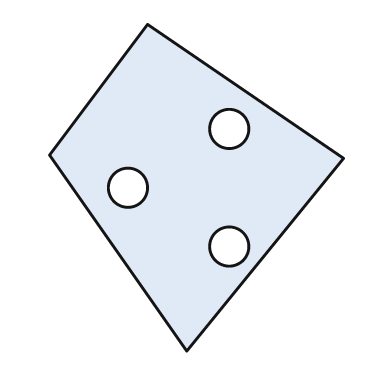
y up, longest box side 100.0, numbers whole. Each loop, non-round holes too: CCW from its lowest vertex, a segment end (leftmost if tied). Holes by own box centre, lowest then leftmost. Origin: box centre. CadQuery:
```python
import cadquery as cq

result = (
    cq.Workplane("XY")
    .moveTo(-3.0, -50.0)
    .lineTo(45.0, 9.0)
    .lineTo(-15.0, 50.0)
    .lineTo(-45.0, 10.0)
    .close()
    .moveTo(10.0, -18.0)
    .circle(6.0)
    .moveTo(-21.0, 0.0)
    .circle(6.0)
    .moveTo(10.0, 18.0)
    .circle(6.0)
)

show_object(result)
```